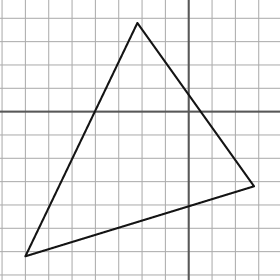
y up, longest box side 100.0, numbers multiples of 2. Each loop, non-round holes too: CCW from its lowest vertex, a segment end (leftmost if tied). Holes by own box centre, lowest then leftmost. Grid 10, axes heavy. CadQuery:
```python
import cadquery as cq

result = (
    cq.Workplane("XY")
    .moveTo(-70.0, -62.0)
    .lineTo(28.0, -32.0)
    .lineTo(-22.0, 38.0)
    .close()
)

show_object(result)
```